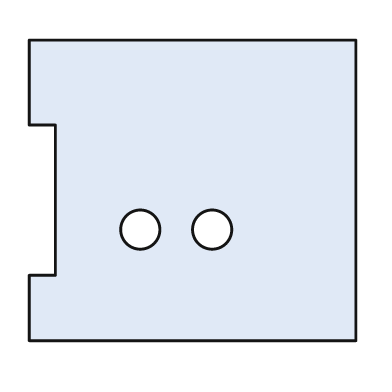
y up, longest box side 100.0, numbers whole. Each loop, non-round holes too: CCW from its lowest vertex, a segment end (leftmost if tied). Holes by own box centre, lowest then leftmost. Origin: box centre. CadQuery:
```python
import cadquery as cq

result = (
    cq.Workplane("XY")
    .moveTo(-50.0, -46.0)
    .lineTo(50.0, -46.0)
    .lineTo(50.0, 46.0)
    .lineTo(-50.0, 46.0)
    .lineTo(-50.0, 20.0)
    .lineTo(-42.0, 20.0)
    .lineTo(-42.0, -26.0)
    .lineTo(-50.0, -26.0)
    .close()
    .moveTo(-16.0, -12.0)
    .circle(6.0)
    .moveTo(6.0, -12.0)
    .circle(6.0)
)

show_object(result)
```